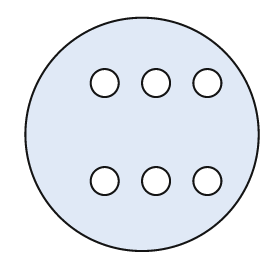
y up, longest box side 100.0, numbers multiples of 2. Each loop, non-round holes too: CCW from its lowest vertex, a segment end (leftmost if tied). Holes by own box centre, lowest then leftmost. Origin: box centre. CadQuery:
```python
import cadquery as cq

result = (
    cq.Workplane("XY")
    .moveTo(0.0, 0.0)
    .circle(50.0)
    .moveTo(-16.0, -20.0)
    .circle(6.0)
    .moveTo(6.0, -20.0)
    .circle(6.0)
    .moveTo(28.0, -20.0)
    .circle(6.0)
    .moveTo(-16.0, 22.0)
    .circle(6.0)
    .moveTo(6.0, 22.0)
    .circle(6.0)
    .moveTo(28.0, 22.0)
    .circle(6.0)
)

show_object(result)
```